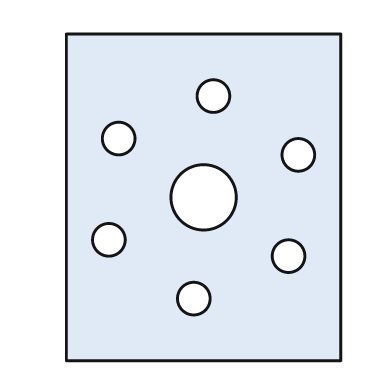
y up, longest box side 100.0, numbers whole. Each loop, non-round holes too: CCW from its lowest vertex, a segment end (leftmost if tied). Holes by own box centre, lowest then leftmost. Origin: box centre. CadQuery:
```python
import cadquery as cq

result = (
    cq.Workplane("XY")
    .moveTo(-42.0, -50.0)
    .lineTo(42.0, -50.0)
    .lineTo(42.0, 50.0)
    .lineTo(-42.0, 50.0)
    .close()
    .moveTo(-3.0, -31.0)
    .circle(5.0)
    .moveTo(26.0, -18.0)
    .circle(5.0)
    .moveTo(-29.0, -13.0)
    .circle(5.0)
    .moveTo(0.0, 0.0)
    .circle(10.0)
    .moveTo(29.0, 13.0)
    .circle(5.0)
    .moveTo(-26.0, 18.0)
    .circle(5.0)
    .moveTo(3.0, 31.0)
    .circle(5.0)
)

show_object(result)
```